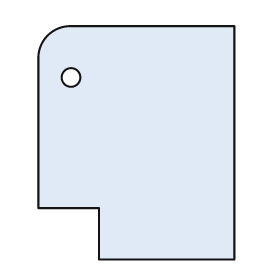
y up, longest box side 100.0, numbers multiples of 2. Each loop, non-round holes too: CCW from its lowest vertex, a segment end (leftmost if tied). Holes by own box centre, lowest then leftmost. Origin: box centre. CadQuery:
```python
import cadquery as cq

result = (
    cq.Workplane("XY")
    .moveTo(-16.0, -50.0)
    .lineTo(42.0, -50.0)
    .lineTo(42.0, 50.0)
    .lineTo(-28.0, 50.0)
    .threePointArc((-38.0, 46.0), (-42.0, 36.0))
    .lineTo(-42.0, -28.0)
    .lineTo(-16.0, -28.0)
    .close()
    .moveTo(-28.0, 28.0)
    .circle(4.0)
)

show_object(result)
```